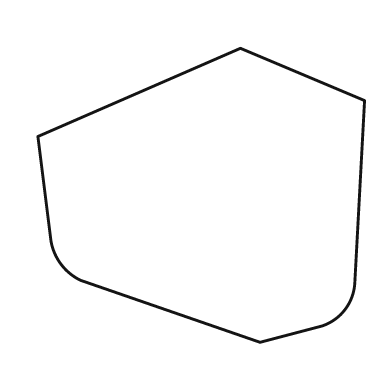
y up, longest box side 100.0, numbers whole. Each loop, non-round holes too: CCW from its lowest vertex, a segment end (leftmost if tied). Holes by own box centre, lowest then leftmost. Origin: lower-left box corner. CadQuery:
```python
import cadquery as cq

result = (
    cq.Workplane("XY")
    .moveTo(68.0, 0.0)
    .lineTo(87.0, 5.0)
    .threePointArc((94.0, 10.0), (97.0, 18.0))
    .lineTo(100.0, 74.0)
    .lineTo(62.0, 90.0)
    .lineTo(0.0, 63.0)
    .lineTo(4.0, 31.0)
    .threePointArc((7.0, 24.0), (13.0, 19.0))
    .close()
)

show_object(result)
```